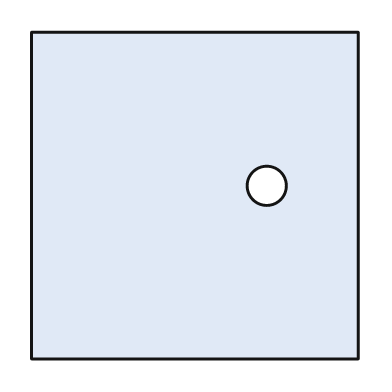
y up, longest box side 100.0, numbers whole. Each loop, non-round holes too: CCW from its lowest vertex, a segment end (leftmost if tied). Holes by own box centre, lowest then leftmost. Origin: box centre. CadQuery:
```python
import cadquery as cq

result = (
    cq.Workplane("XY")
    .moveTo(-50.0, -50.0)
    .lineTo(50.0, -50.0)
    .lineTo(50.0, 50.0)
    .lineTo(-50.0, 50.0)
    .close()
    .moveTo(22.0, 3.0)
    .circle(6.0)
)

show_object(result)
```